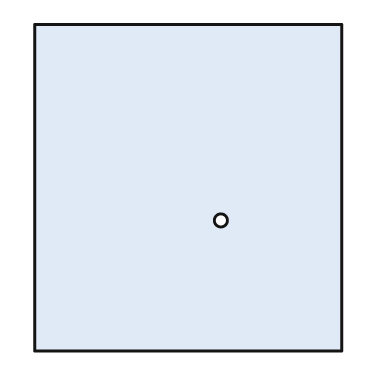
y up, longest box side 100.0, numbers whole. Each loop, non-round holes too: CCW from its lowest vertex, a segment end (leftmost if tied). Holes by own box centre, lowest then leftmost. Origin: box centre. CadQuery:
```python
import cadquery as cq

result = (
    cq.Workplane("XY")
    .moveTo(-47.0, -50.0)
    .lineTo(47.0, -50.0)
    .lineTo(47.0, 50.0)
    .lineTo(-47.0, 50.0)
    .close()
    .moveTo(10.0, -10.0)
    .circle(2.0)
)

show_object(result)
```